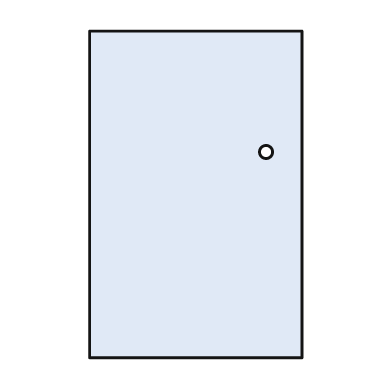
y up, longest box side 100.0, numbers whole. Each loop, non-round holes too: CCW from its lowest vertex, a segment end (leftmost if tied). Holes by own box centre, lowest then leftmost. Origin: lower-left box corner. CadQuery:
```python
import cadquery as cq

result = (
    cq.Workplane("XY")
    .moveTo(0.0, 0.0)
    .lineTo(65.0, 0.0)
    .lineTo(65.0, 100.0)
    .lineTo(0.0, 100.0)
    .close()
    .moveTo(54.0, 63.0)
    .circle(2.0)
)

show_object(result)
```